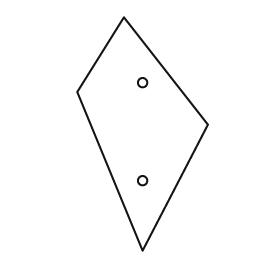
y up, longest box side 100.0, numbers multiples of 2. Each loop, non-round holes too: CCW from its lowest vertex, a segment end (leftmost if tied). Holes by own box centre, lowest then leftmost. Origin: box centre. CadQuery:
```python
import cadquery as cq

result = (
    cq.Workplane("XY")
    .moveTo(0.0, -50.0)
    .lineTo(28.0, 4.0)
    .lineTo(-8.0, 50.0)
    .lineTo(-28.0, 18.0)
    .close()
    .moveTo(0.0, -20.0)
    .circle(2.0)
    .moveTo(0.0, 22.0)
    .circle(2.0)
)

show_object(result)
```